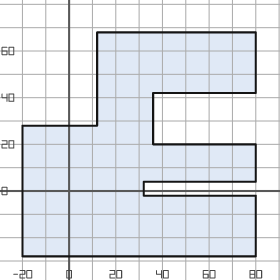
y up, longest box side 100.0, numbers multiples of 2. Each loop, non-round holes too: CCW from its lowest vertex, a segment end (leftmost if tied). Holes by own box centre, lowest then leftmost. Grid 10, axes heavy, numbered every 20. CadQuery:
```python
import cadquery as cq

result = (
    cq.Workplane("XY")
    .moveTo(-20.0, -28.0)
    .lineTo(80.0, -28.0)
    .lineTo(80.0, -2.0)
    .lineTo(32.0, -2.0)
    .lineTo(32.0, 4.0)
    .lineTo(80.0, 4.0)
    .lineTo(80.0, 20.0)
    .lineTo(36.0, 20.0)
    .lineTo(36.0, 42.0)
    .lineTo(80.0, 42.0)
    .lineTo(80.0, 68.0)
    .lineTo(12.0, 68.0)
    .lineTo(12.0, 28.0)
    .lineTo(-20.0, 28.0)
    .close()
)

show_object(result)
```